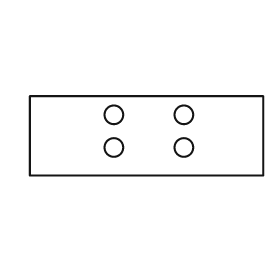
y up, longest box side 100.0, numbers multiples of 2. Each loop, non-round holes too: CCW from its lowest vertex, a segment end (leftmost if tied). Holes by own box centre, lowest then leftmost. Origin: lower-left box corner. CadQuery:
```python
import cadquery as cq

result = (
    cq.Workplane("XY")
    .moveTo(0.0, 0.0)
    .lineTo(100.0, 0.0)
    .lineTo(100.0, 34.0)
    .lineTo(0.0, 34.0)
    .close()
    .moveTo(36.0, 12.0)
    .circle(4.0)
    .moveTo(66.0, 12.0)
    .circle(4.0)
    .moveTo(36.0, 26.0)
    .circle(4.0)
    .moveTo(66.0, 26.0)
    .circle(4.0)
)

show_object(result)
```